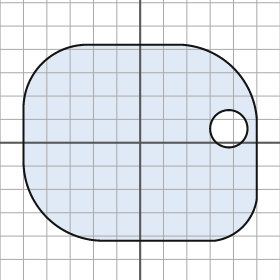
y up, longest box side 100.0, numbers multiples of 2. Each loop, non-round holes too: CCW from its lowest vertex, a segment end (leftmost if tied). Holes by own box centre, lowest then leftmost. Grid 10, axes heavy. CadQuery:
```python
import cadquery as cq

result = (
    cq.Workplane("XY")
    .moveTo(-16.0, -42.0)
    .lineTo(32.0, -42.0)
    .threePointArc((44.0, -36.0), (50.0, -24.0))
    .lineTo(50.0, 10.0)
    .threePointArc((40.0, 32.0), (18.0, 42.0))
    .lineTo(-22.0, 42.0)
    .threePointArc((-42.0, 34.0), (-50.0, 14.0))
    .lineTo(-50.0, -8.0)
    .threePointArc((-40.0, -32.0), (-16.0, -42.0))
    .close()
    .moveTo(38.0, 6.0)
    .circle(8.0)
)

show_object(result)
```